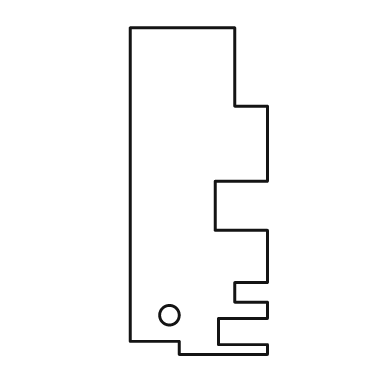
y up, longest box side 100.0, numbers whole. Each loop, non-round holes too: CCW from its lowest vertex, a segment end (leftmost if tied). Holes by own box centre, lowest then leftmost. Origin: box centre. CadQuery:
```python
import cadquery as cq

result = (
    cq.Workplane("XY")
    .moveTo(-6.0, -50.0)
    .lineTo(21.0, -50.0)
    .lineTo(21.0, -47.0)
    .lineTo(6.0, -47.0)
    .lineTo(6.0, -39.0)
    .lineTo(21.0, -39.0)
    .lineTo(21.0, -34.0)
    .lineTo(11.0, -34.0)
    .lineTo(11.0, -28.0)
    .lineTo(21.0, -28.0)
    .lineTo(21.0, -12.0)
    .lineTo(5.0, -12.0)
    .lineTo(5.0, 3.0)
    .lineTo(21.0, 3.0)
    .lineTo(21.0, 26.0)
    .lineTo(11.0, 26.0)
    .lineTo(11.0, 50.0)
    .lineTo(-21.0, 50.0)
    .lineTo(-21.0, -46.0)
    .lineTo(-6.0, -46.0)
    .close()
    .moveTo(-9.0, -38.0)
    .circle(3.0)
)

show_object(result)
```